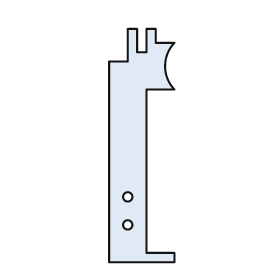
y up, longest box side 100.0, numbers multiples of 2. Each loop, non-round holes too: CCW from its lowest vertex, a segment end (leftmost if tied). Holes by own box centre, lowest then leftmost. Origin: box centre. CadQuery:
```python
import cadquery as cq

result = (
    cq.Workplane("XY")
    .moveTo(-14.0, -50.0)
    .lineTo(14.0, -50.0)
    .lineTo(14.0, -46.0)
    .lineTo(2.0, -46.0)
    .lineTo(2.0, 24.0)
    .lineTo(14.0, 24.0)
    .threePointArc((10.0, 34.0), (14.0, 44.0))
    .lineTo(6.0, 44.0)
    .lineTo(6.0, 50.0)
    .lineTo(2.0, 50.0)
    .lineTo(2.0, 40.0)
    .lineTo(-2.0, 40.0)
    .lineTo(-2.0, 50.0)
    .lineTo(-6.0, 50.0)
    .lineTo(-6.0, 36.0)
    .lineTo(-14.0, 36.0)
    .close()
    .moveTo(-6.0, -34.0)
    .circle(2.0)
    .moveTo(-6.0, -22.0)
    .circle(2.0)
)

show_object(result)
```